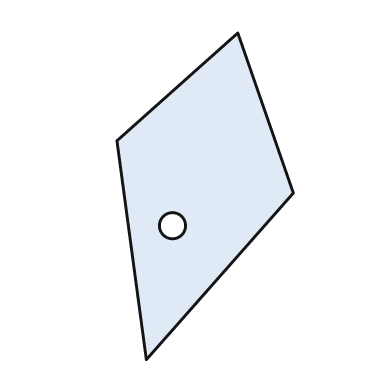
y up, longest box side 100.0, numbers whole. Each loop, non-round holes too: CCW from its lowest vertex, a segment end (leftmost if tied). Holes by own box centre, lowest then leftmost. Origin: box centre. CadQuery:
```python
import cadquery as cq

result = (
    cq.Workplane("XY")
    .moveTo(-18.0, -50.0)
    .lineTo(27.0, 1.0)
    .lineTo(10.0, 50.0)
    .lineTo(-27.0, 17.0)
    .close()
    .moveTo(-10.0, -9.0)
    .circle(4.0)
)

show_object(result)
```